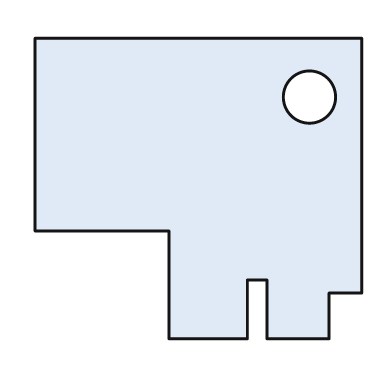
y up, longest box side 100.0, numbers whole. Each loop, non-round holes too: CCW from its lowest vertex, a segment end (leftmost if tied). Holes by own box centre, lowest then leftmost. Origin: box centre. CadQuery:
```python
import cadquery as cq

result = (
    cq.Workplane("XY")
    .moveTo(-9.0, -46.0)
    .lineTo(15.0, -46.0)
    .lineTo(15.0, -28.0)
    .lineTo(21.0, -28.0)
    .lineTo(21.0, -46.0)
    .lineTo(40.0, -46.0)
    .lineTo(40.0, -32.0)
    .lineTo(50.0, -32.0)
    .lineTo(50.0, 46.0)
    .lineTo(-50.0, 46.0)
    .lineTo(-50.0, -13.0)
    .lineTo(-9.0, -13.0)
    .close()
    .moveTo(34.0, 28.0)
    .circle(8.0)
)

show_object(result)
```